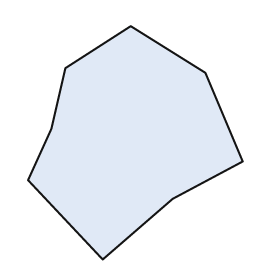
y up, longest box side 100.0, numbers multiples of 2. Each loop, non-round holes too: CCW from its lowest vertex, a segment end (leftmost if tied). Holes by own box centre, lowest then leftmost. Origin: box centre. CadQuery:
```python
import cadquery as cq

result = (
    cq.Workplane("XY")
    .moveTo(-14.0, -50.0)
    .lineTo(16.0, -24.0)
    .lineTo(46.0, -8.0)
    .lineTo(30.0, 30.0)
    .lineTo(-2.0, 50.0)
    .lineTo(-30.0, 32.0)
    .lineTo(-36.0, 6.0)
    .lineTo(-46.0, -16.0)
    .close()
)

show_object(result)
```